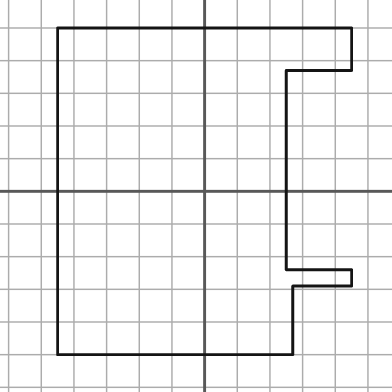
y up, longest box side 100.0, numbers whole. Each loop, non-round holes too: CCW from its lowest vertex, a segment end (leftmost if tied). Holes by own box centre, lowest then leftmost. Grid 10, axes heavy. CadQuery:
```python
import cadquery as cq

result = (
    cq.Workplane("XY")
    .moveTo(-45.0, -50.0)
    .lineTo(27.0, -50.0)
    .lineTo(27.0, -29.0)
    .lineTo(45.0, -29.0)
    .lineTo(45.0, -24.0)
    .lineTo(25.0, -24.0)
    .lineTo(25.0, 37.0)
    .lineTo(45.0, 37.0)
    .lineTo(45.0, 50.0)
    .lineTo(-45.0, 50.0)
    .close()
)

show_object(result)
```